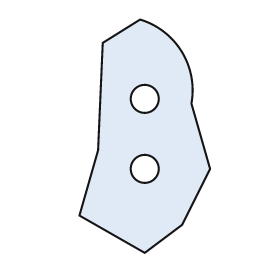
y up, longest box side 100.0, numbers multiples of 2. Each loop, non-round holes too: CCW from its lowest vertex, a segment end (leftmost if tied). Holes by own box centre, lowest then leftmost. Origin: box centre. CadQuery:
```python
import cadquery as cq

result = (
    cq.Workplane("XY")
    .moveTo(0.0, -50.0)
    .lineTo(16.0, -38.0)
    .lineTo(28.0, -14.0)
    .lineTo(20.0, 14.0)
    .threePointArc((16.0, 36.0), (-2.0, 50.0))
    .lineTo(-18.0, 40.0)
    .lineTo(-20.0, -6.0)
    .lineTo(-28.0, -34.0)
    .close()
    .moveTo(0.0, -14.0)
    .circle(6.0)
    .moveTo(0.0, 16.0)
    .circle(6.0)
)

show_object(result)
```